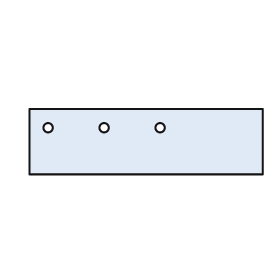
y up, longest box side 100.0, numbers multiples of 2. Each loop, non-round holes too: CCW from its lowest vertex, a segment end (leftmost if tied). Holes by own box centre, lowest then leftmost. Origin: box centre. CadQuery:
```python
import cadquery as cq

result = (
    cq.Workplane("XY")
    .moveTo(-50.0, -14.0)
    .lineTo(50.0, -14.0)
    .lineTo(50.0, 14.0)
    .lineTo(-50.0, 14.0)
    .close()
    .moveTo(-42.0, 6.0)
    .circle(2.0)
    .moveTo(-18.0, 6.0)
    .circle(2.0)
    .moveTo(6.0, 6.0)
    .circle(2.0)
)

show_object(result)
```